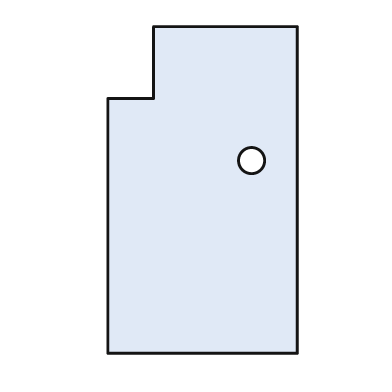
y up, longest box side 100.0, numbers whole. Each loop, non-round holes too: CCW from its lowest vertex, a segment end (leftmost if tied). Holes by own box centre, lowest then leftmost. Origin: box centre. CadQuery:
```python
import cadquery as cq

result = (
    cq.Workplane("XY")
    .moveTo(-29.0, -50.0)
    .lineTo(29.0, -50.0)
    .lineTo(29.0, 50.0)
    .lineTo(-15.0, 50.0)
    .lineTo(-15.0, 28.0)
    .lineTo(-29.0, 28.0)
    .close()
    .moveTo(15.0, 9.0)
    .circle(4.0)
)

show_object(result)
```